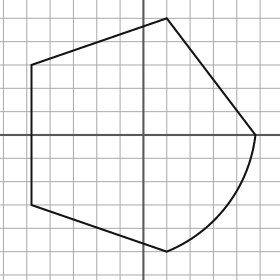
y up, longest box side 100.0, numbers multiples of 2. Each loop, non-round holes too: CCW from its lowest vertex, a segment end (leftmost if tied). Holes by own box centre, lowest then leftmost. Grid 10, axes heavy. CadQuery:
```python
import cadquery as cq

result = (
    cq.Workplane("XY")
    .moveTo(10.0, -50.0)
    .threePointArc((36.0, -30.0), (48.0, 0.0))
    .lineTo(10.0, 50.0)
    .lineTo(-48.0, 30.0)
    .lineTo(-48.0, -30.0)
    .close()
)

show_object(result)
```